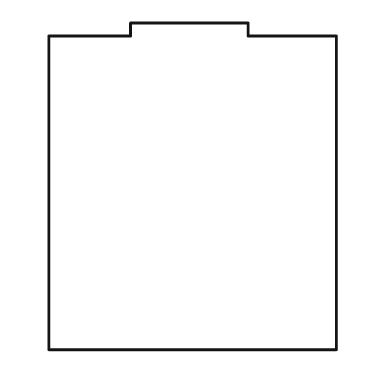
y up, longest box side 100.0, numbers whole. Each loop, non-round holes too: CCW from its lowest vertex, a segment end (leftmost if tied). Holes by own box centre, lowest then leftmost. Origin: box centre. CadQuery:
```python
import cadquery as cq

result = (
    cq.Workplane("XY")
    .moveTo(-44.0, -50.0)
    .lineTo(44.0, -50.0)
    .lineTo(44.0, 46.0)
    .lineTo(17.0, 46.0)
    .lineTo(17.0, 50.0)
    .lineTo(-19.0, 50.0)
    .lineTo(-19.0, 46.0)
    .lineTo(-44.0, 46.0)
    .close()
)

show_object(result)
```